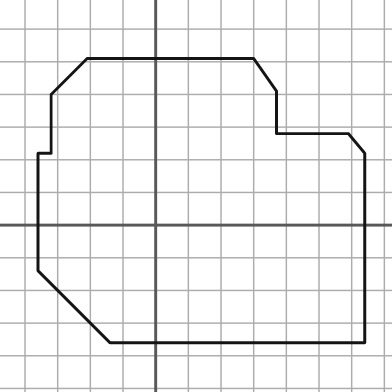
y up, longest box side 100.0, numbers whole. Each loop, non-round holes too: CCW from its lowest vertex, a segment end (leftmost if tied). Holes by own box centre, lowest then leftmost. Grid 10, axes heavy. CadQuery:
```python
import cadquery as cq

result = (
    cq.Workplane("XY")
    .moveTo(-14.0, -36.0)
    .lineTo(64.0, -36.0)
    .lineTo(64.0, 22.0)
    .lineTo(59.0, 28.0)
    .lineTo(37.0, 28.0)
    .lineTo(37.0, 41.0)
    .lineTo(30.0, 51.0)
    .lineTo(-21.0, 51.0)
    .lineTo(-32.0, 40.0)
    .lineTo(-32.0, 22.0)
    .lineTo(-36.0, 22.0)
    .lineTo(-36.0, -14.0)
    .close()
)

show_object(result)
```